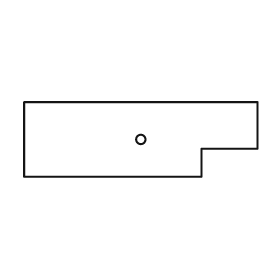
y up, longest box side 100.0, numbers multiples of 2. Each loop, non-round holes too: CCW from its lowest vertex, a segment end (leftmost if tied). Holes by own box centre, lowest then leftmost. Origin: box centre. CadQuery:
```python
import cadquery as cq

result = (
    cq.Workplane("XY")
    .moveTo(-50.0, -16.0)
    .lineTo(26.0, -16.0)
    .lineTo(26.0, -4.0)
    .lineTo(50.0, -4.0)
    .lineTo(50.0, 16.0)
    .lineTo(-50.0, 16.0)
    .close()
    .moveTo(0.0, 0.0)
    .circle(2.0)
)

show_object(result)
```